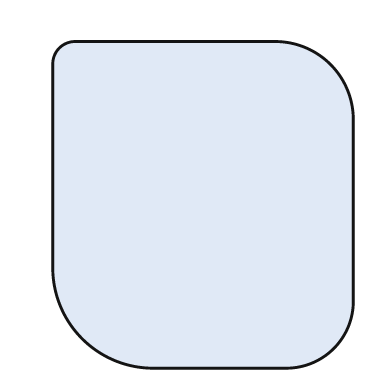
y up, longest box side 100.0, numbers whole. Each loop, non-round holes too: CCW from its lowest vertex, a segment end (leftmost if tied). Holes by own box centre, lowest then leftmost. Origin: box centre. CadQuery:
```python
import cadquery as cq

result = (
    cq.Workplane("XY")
    .moveTo(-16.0, -50.0)
    .lineTo(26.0, -50.0)
    .threePointArc((40.0, -44.0), (46.0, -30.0))
    .lineTo(46.0, 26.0)
    .threePointArc((39.0, 43.0), (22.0, 50.0))
    .lineTo(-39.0, 50.0)
    .threePointArc((-44.0, 48.0), (-46.0, 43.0))
    .lineTo(-46.0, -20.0)
    .threePointArc((-37.0, -41.0), (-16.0, -50.0))
    .close()
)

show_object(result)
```